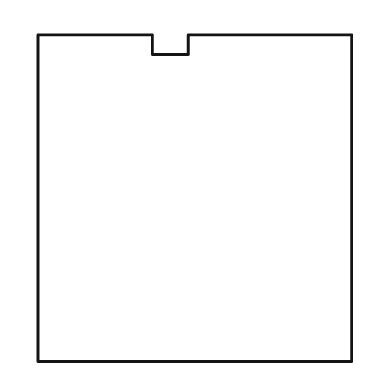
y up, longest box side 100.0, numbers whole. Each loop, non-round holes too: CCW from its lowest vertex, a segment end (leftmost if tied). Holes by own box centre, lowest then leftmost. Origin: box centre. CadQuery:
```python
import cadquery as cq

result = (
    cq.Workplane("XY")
    .moveTo(-48.0, -50.0)
    .lineTo(48.0, -50.0)
    .lineTo(48.0, 50.0)
    .lineTo(-2.0, 50.0)
    .lineTo(-2.0, 44.0)
    .lineTo(-13.0, 44.0)
    .lineTo(-13.0, 50.0)
    .lineTo(-48.0, 50.0)
    .close()
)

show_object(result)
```